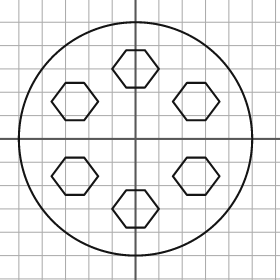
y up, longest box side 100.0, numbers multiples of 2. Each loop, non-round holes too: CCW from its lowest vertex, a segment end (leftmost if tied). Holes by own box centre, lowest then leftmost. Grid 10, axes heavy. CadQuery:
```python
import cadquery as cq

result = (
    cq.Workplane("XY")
    .moveTo(0.0, 0.0)
    .circle(50.0)
    .moveTo(-4.0, -38.0)
    .lineTo(4.0, -38.0)
    .lineTo(10.0, -30.0)
    .lineTo(4.0, -22.0)
    .lineTo(-4.0, -22.0)
    .lineTo(-10.0, -30.0)
    .close()
    .moveTo(-30.0, -24.0)
    .lineTo(-22.0, -24.0)
    .lineTo(-16.0, -16.0)
    .lineTo(-22.0, -8.0)
    .lineTo(-30.0, -8.0)
    .lineTo(-36.0, -16.0)
    .close()
    .moveTo(22.0, -24.0)
    .lineTo(30.0, -24.0)
    .lineTo(36.0, -16.0)
    .lineTo(30.0, -8.0)
    .lineTo(22.0, -8.0)
    .lineTo(16.0, -16.0)
    .close()
    .moveTo(-30.0, 8.0)
    .lineTo(-22.0, 8.0)
    .lineTo(-16.0, 16.0)
    .lineTo(-22.0, 24.0)
    .lineTo(-30.0, 24.0)
    .lineTo(-36.0, 16.0)
    .close()
    .moveTo(22.0, 8.0)
    .lineTo(30.0, 8.0)
    .lineTo(36.0, 16.0)
    .lineTo(30.0, 24.0)
    .lineTo(22.0, 24.0)
    .lineTo(16.0, 16.0)
    .close()
    .moveTo(-4.0, 22.0)
    .lineTo(4.0, 22.0)
    .lineTo(10.0, 30.0)
    .lineTo(4.0, 38.0)
    .lineTo(-4.0, 38.0)
    .lineTo(-10.0, 30.0)
    .close()
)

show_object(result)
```